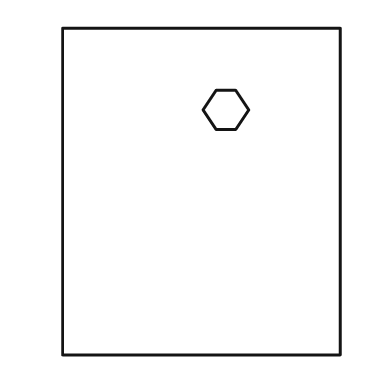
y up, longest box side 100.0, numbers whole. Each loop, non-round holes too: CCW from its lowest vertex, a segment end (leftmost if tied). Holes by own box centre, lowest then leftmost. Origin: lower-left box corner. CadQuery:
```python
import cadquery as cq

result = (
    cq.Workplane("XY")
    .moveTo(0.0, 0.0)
    .lineTo(85.0, 0.0)
    .lineTo(85.0, 100.0)
    .lineTo(0.0, 100.0)
    .close()
    .moveTo(47.0, 69.0)
    .lineTo(53.0, 69.0)
    .lineTo(57.0, 75.0)
    .lineTo(53.0, 81.0)
    .lineTo(47.0, 81.0)
    .lineTo(43.0, 75.0)
    .close()
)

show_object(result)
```